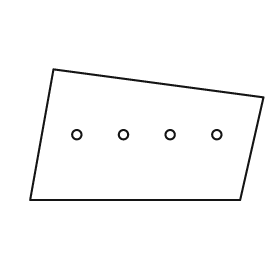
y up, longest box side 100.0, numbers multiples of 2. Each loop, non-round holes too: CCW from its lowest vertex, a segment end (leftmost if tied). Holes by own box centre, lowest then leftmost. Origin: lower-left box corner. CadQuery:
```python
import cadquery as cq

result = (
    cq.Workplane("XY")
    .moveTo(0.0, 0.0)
    .lineTo(90.0, 0.0)
    .lineTo(100.0, 44.0)
    .lineTo(10.0, 56.0)
    .close()
    .moveTo(20.0, 28.0)
    .circle(2.0)
    .moveTo(40.0, 28.0)
    .circle(2.0)
    .moveTo(60.0, 28.0)
    .circle(2.0)
    .moveTo(80.0, 28.0)
    .circle(2.0)
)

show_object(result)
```